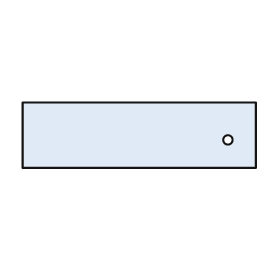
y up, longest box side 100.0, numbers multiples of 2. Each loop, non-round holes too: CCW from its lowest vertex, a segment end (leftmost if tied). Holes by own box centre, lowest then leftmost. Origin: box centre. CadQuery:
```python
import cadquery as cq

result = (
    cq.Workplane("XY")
    .moveTo(-50.0, -14.0)
    .lineTo(50.0, -14.0)
    .lineTo(50.0, 14.0)
    .lineTo(-50.0, 14.0)
    .close()
    .moveTo(38.0, -2.0)
    .circle(2.0)
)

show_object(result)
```